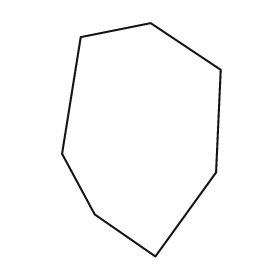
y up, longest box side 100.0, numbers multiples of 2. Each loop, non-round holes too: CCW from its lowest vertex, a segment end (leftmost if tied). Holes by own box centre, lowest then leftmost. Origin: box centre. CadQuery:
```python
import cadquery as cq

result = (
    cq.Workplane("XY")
    .moveTo(6.0, -50.0)
    .lineTo(32.0, -14.0)
    .lineTo(34.0, 30.0)
    .lineTo(4.0, 50.0)
    .lineTo(-26.0, 44.0)
    .lineTo(-34.0, -6.0)
    .lineTo(-20.0, -32.0)
    .close()
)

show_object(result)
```